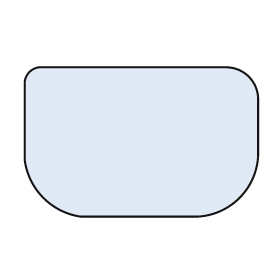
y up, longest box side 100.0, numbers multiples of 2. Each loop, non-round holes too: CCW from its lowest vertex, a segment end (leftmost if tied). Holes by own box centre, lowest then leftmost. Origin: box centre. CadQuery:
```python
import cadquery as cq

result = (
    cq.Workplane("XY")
    .moveTo(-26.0, -32.0)
    .lineTo(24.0, -32.0)
    .threePointArc((42.0, -24.0), (50.0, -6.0))
    .lineTo(50.0, 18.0)
    .threePointArc((46.0, 28.0), (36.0, 32.0))
    .lineTo(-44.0, 32.0)
    .threePointArc((-48.0, 30.0), (-50.0, 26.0))
    .lineTo(-50.0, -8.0)
    .threePointArc((-42.0, -24.0), (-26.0, -32.0))
    .close()
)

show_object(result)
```